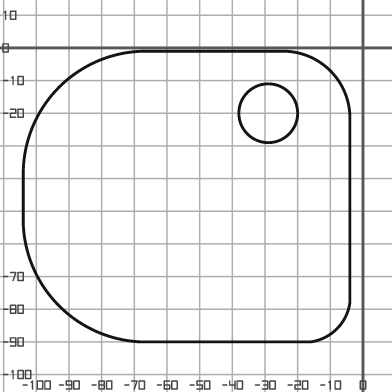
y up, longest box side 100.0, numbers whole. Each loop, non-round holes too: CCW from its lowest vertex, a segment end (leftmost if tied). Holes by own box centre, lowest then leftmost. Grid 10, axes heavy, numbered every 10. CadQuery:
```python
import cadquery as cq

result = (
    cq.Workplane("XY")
    .moveTo(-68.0, -90.0)
    .lineTo(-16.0, -90.0)
    .threePointArc((-8.0, -86.0), (-4.0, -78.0))
    .lineTo(-4.0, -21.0)
    .threePointArc((-10.0, -7.0), (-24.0, -1.0))
    .lineTo(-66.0, -1.0)
    .threePointArc((-93.0, -12.0), (-104.0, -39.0))
    .lineTo(-104.0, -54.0)
    .threePointArc((-93.0, -79.0), (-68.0, -90.0))
    .close()
    .moveTo(-29.0, -20.0)
    .circle(9.0)
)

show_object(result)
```